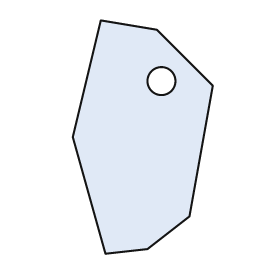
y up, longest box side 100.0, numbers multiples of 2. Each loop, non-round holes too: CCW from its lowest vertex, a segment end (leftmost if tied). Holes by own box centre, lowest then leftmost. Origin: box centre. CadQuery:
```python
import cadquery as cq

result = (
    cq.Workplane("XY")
    .moveTo(-16.0, -50.0)
    .lineTo(2.0, -48.0)
    .lineTo(20.0, -34.0)
    .lineTo(30.0, 22.0)
    .lineTo(6.0, 46.0)
    .lineTo(-18.0, 50.0)
    .lineTo(-30.0, 0.0)
    .close()
    .moveTo(8.0, 24.0)
    .circle(6.0)
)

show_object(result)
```